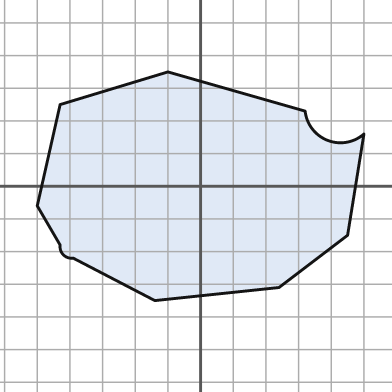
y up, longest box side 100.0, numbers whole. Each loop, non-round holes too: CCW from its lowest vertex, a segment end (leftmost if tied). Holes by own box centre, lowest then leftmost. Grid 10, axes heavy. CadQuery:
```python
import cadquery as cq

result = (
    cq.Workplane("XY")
    .moveTo(-14.0, -35.0)
    .lineTo(24.0, -31.0)
    .lineTo(45.0, -15.0)
    .lineTo(50.0, 16.0)
    .threePointArc((39.0, 14.0), (32.0, 23.0))
    .lineTo(-10.0, 35.0)
    .lineTo(-43.0, 25.0)
    .lineTo(-50.0, -6.0)
    .lineTo(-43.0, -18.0)
    .threePointArc((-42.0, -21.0), (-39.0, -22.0))
    .close()
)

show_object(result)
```